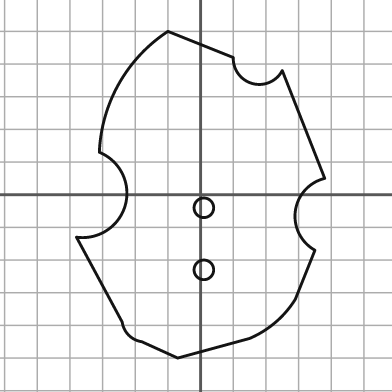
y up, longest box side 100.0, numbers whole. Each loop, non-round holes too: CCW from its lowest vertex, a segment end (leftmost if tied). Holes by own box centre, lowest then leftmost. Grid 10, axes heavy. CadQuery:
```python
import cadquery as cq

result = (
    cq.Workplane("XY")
    .moveTo(-7.0, -50.0)
    .lineTo(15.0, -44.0)
    .threePointArc((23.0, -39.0), (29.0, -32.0))
    .lineTo(35.0, -17.0)
    .threePointArc((29.0, -5.0), (38.0, 5.0))
    .lineTo(25.0, 38.0)
    .threePointArc((16.0, 34.0), (10.0, 42.0))
    .lineTo(-10.0, 50.0)
    .threePointArc((-25.0, 34.0), (-31.0, 13.0))
    .threePointArc((-23.0, -3.0), (-38.0, -13.0))
    .lineTo(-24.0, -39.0)
    .threePointArc((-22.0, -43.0), (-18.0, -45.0))
    .close()
    .moveTo(1.0, -23.0)
    .circle(3.0)
    .moveTo(1.0, -4.0)
    .circle(3.0)
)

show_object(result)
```